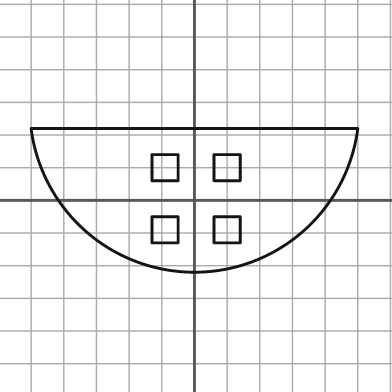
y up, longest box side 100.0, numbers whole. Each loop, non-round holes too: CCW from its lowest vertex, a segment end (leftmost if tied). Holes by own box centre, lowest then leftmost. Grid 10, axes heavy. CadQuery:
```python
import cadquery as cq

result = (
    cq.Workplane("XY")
    .moveTo(-50.0, 22.0)
    .threePointArc((0.0, -22.0), (50.0, 22.0))
    .close()
    .moveTo(-13.0, -13.0)
    .lineTo(-5.0, -13.0)
    .lineTo(-5.0, -5.0)
    .lineTo(-13.0, -5.0)
    .close()
    .moveTo(6.0, -13.0)
    .lineTo(14.0, -13.0)
    .lineTo(14.0, -5.0)
    .lineTo(6.0, -5.0)
    .close()
    .moveTo(-13.0, 6.0)
    .lineTo(-5.0, 6.0)
    .lineTo(-5.0, 14.0)
    .lineTo(-13.0, 14.0)
    .close()
    .moveTo(6.0, 6.0)
    .lineTo(14.0, 6.0)
    .lineTo(14.0, 14.0)
    .lineTo(6.0, 14.0)
    .close()
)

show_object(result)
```